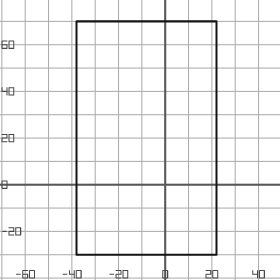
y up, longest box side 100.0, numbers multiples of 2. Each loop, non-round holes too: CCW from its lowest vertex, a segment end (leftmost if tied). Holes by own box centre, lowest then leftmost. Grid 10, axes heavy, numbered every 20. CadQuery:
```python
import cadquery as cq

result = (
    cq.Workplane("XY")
    .moveTo(-38.0, -30.0)
    .lineTo(22.0, -30.0)
    .lineTo(22.0, 70.0)
    .lineTo(-38.0, 70.0)
    .close()
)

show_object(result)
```